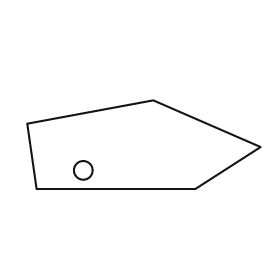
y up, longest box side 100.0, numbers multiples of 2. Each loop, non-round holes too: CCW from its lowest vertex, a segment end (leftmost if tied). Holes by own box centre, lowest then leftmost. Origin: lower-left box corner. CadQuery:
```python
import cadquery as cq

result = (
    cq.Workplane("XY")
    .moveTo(4.0, 0.0)
    .lineTo(72.0, 0.0)
    .lineTo(100.0, 18.0)
    .lineTo(54.0, 38.0)
    .lineTo(0.0, 28.0)
    .close()
    .moveTo(24.0, 8.0)
    .circle(4.0)
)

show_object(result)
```